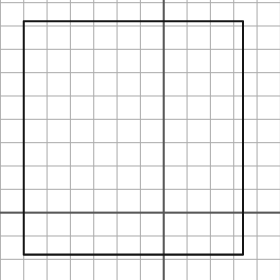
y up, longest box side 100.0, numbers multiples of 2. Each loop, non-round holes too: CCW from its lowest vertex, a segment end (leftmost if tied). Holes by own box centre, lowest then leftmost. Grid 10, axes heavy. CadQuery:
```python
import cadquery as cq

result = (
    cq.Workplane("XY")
    .moveTo(-60.0, -18.0)
    .lineTo(34.0, -18.0)
    .lineTo(34.0, 82.0)
    .lineTo(-60.0, 82.0)
    .close()
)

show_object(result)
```